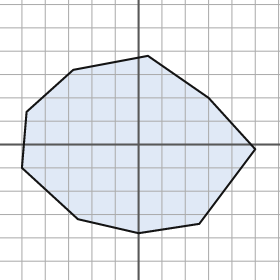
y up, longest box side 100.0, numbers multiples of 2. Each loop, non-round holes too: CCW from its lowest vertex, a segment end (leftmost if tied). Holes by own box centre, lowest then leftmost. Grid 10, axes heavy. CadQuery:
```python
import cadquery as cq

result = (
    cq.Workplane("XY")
    .moveTo(0.0, -38.0)
    .lineTo(26.0, -34.0)
    .lineTo(50.0, -2.0)
    .lineTo(30.0, 20.0)
    .lineTo(4.0, 38.0)
    .lineTo(-28.0, 32.0)
    .lineTo(-48.0, 14.0)
    .lineTo(-50.0, -10.0)
    .lineTo(-26.0, -32.0)
    .close()
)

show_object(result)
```